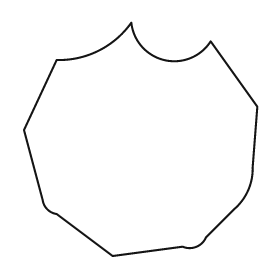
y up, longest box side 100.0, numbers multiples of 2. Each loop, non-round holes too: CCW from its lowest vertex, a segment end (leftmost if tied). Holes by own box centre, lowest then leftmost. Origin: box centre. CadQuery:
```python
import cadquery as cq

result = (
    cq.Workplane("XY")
    .moveTo(-12.0, -50.0)
    .lineTo(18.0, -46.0)
    .threePointArc((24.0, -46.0), (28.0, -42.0))
    .lineTo(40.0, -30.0)
    .threePointArc((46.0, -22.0), (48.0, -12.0))
    .lineTo(50.0, 14.0)
    .lineTo(30.0, 42.0)
    .threePointArc((10.0, 34.0), (-4.0, 50.0))
    .threePointArc((-18.0, 38.0), (-36.0, 34.0))
    .lineTo(-50.0, 4.0)
    .lineTo(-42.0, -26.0)
    .threePointArc((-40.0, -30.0), (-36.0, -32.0))
    .close()
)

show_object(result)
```